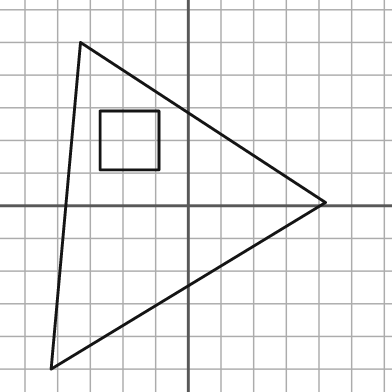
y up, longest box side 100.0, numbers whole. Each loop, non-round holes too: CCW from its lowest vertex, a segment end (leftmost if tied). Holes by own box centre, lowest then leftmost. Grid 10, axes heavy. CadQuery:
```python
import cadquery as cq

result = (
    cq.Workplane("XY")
    .moveTo(-42.0, -50.0)
    .lineTo(42.0, 1.0)
    .lineTo(-33.0, 50.0)
    .close()
    .moveTo(-27.0, 11.0)
    .lineTo(-9.0, 11.0)
    .lineTo(-9.0, 29.0)
    .lineTo(-27.0, 29.0)
    .close()
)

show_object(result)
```